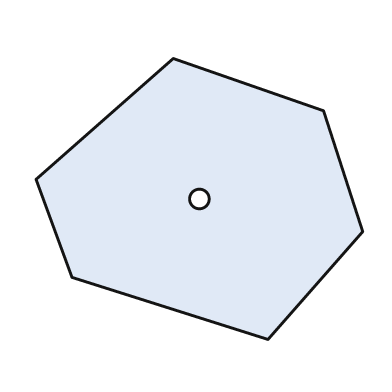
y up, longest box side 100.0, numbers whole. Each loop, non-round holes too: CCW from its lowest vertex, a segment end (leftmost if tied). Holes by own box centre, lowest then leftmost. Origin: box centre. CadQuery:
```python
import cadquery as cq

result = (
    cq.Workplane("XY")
    .moveTo(21.0, -43.0)
    .lineTo(50.0, -10.0)
    .lineTo(38.0, 27.0)
    .lineTo(-8.0, 43.0)
    .lineTo(-50.0, 6.0)
    .lineTo(-39.0, -24.0)
    .close()
    .moveTo(0.0, 0.0)
    .circle(3.0)
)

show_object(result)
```